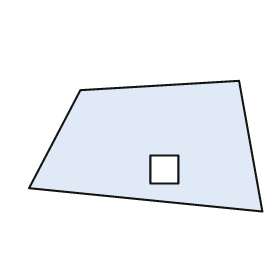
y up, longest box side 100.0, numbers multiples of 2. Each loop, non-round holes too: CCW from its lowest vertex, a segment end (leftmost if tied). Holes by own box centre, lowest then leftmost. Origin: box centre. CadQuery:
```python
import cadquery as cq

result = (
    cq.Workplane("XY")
    .moveTo(50.0, -28.0)
    .lineTo(40.0, 28.0)
    .lineTo(-28.0, 24.0)
    .lineTo(-50.0, -18.0)
    .close()
    .moveTo(2.0, -16.0)
    .lineTo(14.0, -16.0)
    .lineTo(14.0, -4.0)
    .lineTo(2.0, -4.0)
    .close()
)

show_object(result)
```